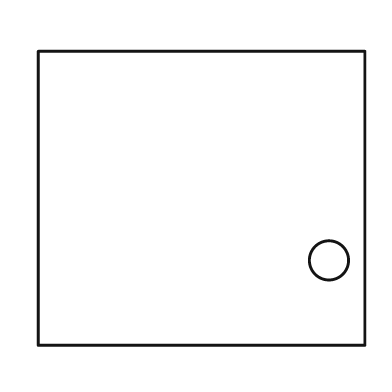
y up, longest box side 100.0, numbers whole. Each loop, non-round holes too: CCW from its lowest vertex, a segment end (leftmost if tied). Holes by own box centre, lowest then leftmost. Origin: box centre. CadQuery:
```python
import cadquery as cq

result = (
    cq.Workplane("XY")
    .moveTo(-50.0, -45.0)
    .lineTo(50.0, -45.0)
    .lineTo(50.0, 45.0)
    .lineTo(-50.0, 45.0)
    .close()
    .moveTo(39.0, -19.0)
    .circle(6.0)
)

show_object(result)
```